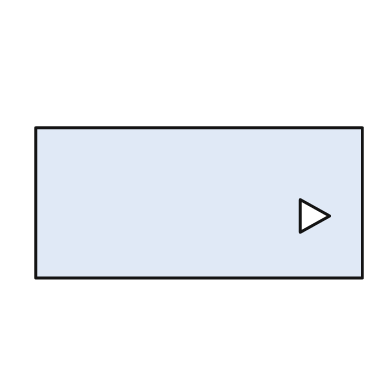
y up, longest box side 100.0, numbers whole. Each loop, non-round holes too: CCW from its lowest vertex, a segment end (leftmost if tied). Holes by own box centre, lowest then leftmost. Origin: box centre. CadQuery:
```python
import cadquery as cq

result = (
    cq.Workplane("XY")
    .moveTo(-50.0, -23.0)
    .lineTo(50.0, -23.0)
    .lineTo(50.0, 23.0)
    .lineTo(-50.0, 23.0)
    .close()
    .moveTo(31.0, -9.0)
    .lineTo(40.0, -4.0)
    .lineTo(31.0, 1.0)
    .close()
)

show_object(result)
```